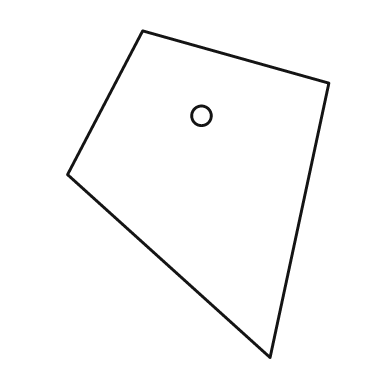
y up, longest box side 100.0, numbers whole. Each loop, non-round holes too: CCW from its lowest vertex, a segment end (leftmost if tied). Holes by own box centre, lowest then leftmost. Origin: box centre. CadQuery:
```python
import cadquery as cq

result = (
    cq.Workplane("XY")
    .moveTo(22.0, -50.0)
    .lineTo(40.0, 34.0)
    .lineTo(-17.0, 50.0)
    .lineTo(-40.0, 6.0)
    .close()
    .moveTo(1.0, 24.0)
    .circle(3.0)
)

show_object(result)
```